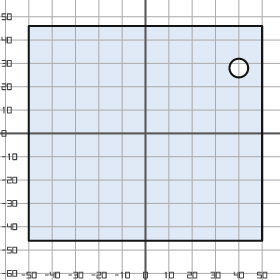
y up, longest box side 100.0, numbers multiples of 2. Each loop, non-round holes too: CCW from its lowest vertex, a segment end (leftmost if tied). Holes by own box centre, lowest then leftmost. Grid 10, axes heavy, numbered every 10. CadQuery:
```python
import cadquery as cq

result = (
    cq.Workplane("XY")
    .moveTo(-50.0, -46.0)
    .lineTo(50.0, -46.0)
    .lineTo(50.0, 46.0)
    .lineTo(-50.0, 46.0)
    .close()
    .moveTo(40.0, 28.0)
    .circle(4.0)
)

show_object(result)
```